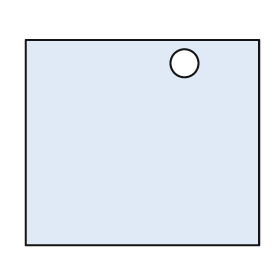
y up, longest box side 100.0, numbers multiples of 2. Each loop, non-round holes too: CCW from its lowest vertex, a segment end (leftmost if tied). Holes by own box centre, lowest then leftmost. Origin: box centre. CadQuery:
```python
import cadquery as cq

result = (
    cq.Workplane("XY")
    .moveTo(-50.0, -44.0)
    .lineTo(50.0, -44.0)
    .lineTo(50.0, 44.0)
    .lineTo(-50.0, 44.0)
    .close()
    .moveTo(18.0, 34.0)
    .circle(6.0)
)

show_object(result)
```